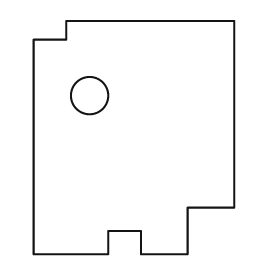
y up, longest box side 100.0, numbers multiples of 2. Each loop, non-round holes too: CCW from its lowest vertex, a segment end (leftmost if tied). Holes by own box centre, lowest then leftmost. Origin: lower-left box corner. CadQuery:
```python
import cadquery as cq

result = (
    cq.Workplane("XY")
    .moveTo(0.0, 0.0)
    .lineTo(32.0, 0.0)
    .lineTo(32.0, 10.0)
    .lineTo(46.0, 10.0)
    .lineTo(46.0, 0.0)
    .lineTo(66.0, 0.0)
    .lineTo(66.0, 20.0)
    .lineTo(86.0, 20.0)
    .lineTo(86.0, 100.0)
    .lineTo(14.0, 100.0)
    .lineTo(14.0, 92.0)
    .lineTo(0.0, 92.0)
    .close()
    .moveTo(24.0, 68.0)
    .circle(8.0)
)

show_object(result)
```